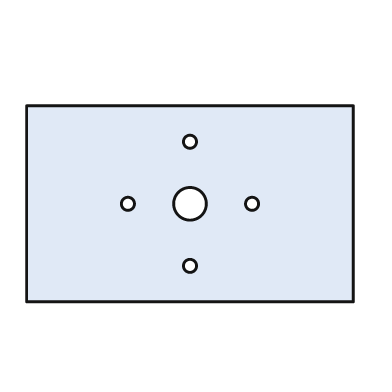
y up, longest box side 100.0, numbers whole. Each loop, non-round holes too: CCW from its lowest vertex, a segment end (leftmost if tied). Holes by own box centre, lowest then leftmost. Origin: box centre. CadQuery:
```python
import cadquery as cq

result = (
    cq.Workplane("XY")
    .moveTo(-50.0, -30.0)
    .lineTo(50.0, -30.0)
    .lineTo(50.0, 30.0)
    .lineTo(-50.0, 30.0)
    .close()
    .moveTo(0.0, -19.0)
    .circle(2.0)
    .moveTo(-19.0, 0.0)
    .circle(2.0)
    .moveTo(0.0, 0.0)
    .circle(5.0)
    .moveTo(19.0, 0.0)
    .circle(2.0)
    .moveTo(0.0, 19.0)
    .circle(2.0)
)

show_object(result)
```